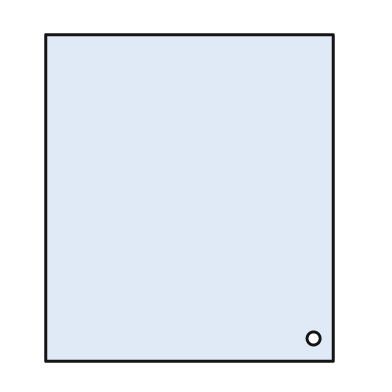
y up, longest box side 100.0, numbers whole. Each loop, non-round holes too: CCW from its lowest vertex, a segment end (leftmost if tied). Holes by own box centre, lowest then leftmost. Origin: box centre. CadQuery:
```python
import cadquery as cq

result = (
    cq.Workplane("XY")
    .moveTo(-44.0, -50.0)
    .lineTo(44.0, -50.0)
    .lineTo(44.0, 50.0)
    .lineTo(-44.0, 50.0)
    .close()
    .moveTo(38.0, -43.0)
    .circle(2.0)
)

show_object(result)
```